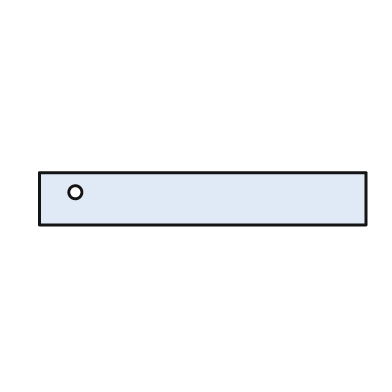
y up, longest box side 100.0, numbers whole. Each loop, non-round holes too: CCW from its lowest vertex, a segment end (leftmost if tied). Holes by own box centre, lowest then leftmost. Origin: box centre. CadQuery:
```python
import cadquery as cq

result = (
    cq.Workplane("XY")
    .moveTo(-50.0, -8.0)
    .lineTo(50.0, -8.0)
    .lineTo(50.0, 8.0)
    .lineTo(-50.0, 8.0)
    .close()
    .moveTo(-39.0, 2.0)
    .circle(2.0)
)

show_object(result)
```